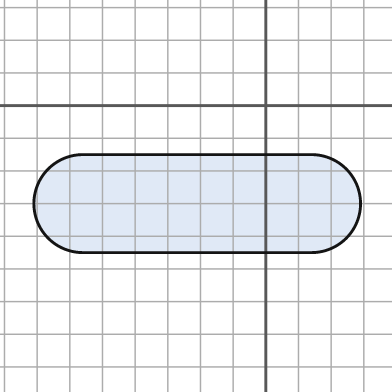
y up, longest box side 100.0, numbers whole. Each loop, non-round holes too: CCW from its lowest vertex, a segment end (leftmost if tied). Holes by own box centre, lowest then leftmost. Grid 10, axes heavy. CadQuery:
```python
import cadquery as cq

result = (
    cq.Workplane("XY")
    .moveTo(-56.0, -45.0)
    .lineTo(14.0, -45.0)
    .threePointArc((29.0, -30.0), (14.0, -15.0))
    .lineTo(-56.0, -15.0)
    .threePointArc((-71.0, -30.0), (-56.0, -45.0))
    .close()
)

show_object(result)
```